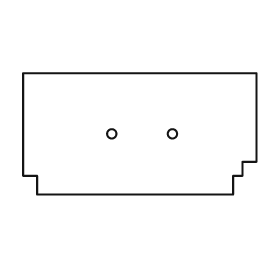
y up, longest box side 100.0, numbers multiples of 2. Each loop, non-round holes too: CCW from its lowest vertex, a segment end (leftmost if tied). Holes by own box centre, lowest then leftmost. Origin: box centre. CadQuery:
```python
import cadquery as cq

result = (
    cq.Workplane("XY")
    .moveTo(-44.0, -26.0)
    .lineTo(40.0, -26.0)
    .lineTo(40.0, -18.0)
    .lineTo(44.0, -18.0)
    .lineTo(44.0, -12.0)
    .lineTo(50.0, -12.0)
    .lineTo(50.0, 26.0)
    .lineTo(-50.0, 26.0)
    .lineTo(-50.0, -18.0)
    .lineTo(-44.0, -18.0)
    .close()
    .moveTo(-12.0, 0.0)
    .circle(2.0)
    .moveTo(14.0, 0.0)
    .circle(2.0)
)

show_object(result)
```